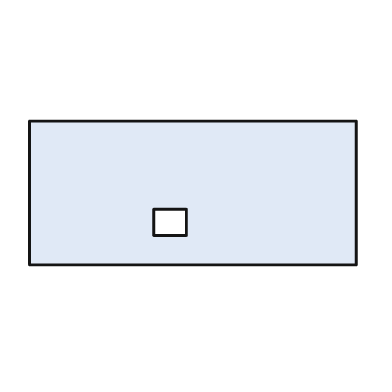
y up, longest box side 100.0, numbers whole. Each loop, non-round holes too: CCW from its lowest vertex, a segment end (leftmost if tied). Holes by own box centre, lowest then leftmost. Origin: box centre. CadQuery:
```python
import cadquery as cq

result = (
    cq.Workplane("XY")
    .moveTo(-50.0, -22.0)
    .lineTo(50.0, -22.0)
    .lineTo(50.0, 22.0)
    .lineTo(-50.0, 22.0)
    .close()
    .moveTo(-12.0, -13.0)
    .lineTo(-2.0, -13.0)
    .lineTo(-2.0, -5.0)
    .lineTo(-12.0, -5.0)
    .close()
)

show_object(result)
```